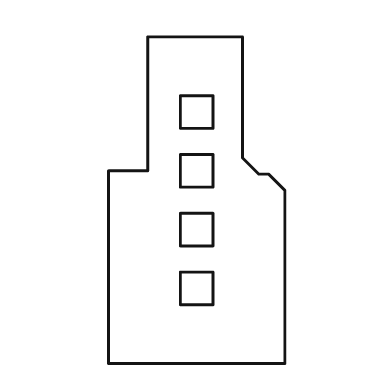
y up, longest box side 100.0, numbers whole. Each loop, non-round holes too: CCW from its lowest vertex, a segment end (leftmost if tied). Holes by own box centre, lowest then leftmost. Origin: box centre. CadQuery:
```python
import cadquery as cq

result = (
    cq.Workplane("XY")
    .moveTo(-27.0, -50.0)
    .lineTo(27.0, -50.0)
    .lineTo(27.0, 3.0)
    .lineTo(22.0, 8.0)
    .lineTo(19.0, 8.0)
    .lineTo(14.0, 13.0)
    .lineTo(14.0, 50.0)
    .lineTo(-15.0, 50.0)
    .lineTo(-15.0, 9.0)
    .lineTo(-27.0, 9.0)
    .close()
    .moveTo(-5.0, -32.0)
    .lineTo(5.0, -32.0)
    .lineTo(5.0, -22.0)
    .lineTo(-5.0, -22.0)
    .close()
    .moveTo(-5.0, -14.0)
    .lineTo(5.0, -14.0)
    .lineTo(5.0, -4.0)
    .lineTo(-5.0, -4.0)
    .close()
    .moveTo(-5.0, 4.0)
    .lineTo(5.0, 4.0)
    .lineTo(5.0, 14.0)
    .lineTo(-5.0, 14.0)
    .close()
    .moveTo(-5.0, 22.0)
    .lineTo(5.0, 22.0)
    .lineTo(5.0, 32.0)
    .lineTo(-5.0, 32.0)
    .close()
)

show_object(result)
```